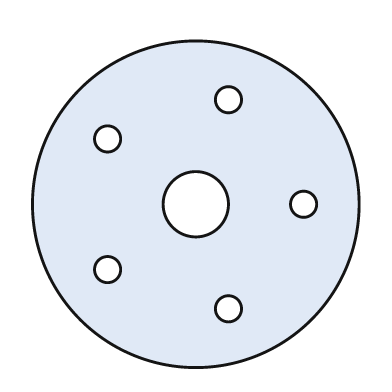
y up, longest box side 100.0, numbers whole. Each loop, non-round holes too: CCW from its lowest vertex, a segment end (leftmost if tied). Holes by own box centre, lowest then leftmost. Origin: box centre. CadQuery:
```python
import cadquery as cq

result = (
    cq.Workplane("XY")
    .moveTo(0.0, 0.0)
    .circle(50.0)
    .moveTo(10.0, -32.0)
    .circle(4.0)
    .moveTo(-27.0, -20.0)
    .circle(4.0)
    .moveTo(0.0, 0.0)
    .circle(10.0)
    .moveTo(33.0, 0.0)
    .circle(4.0)
    .moveTo(-27.0, 20.0)
    .circle(4.0)
    .moveTo(10.0, 32.0)
    .circle(4.0)
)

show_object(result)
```